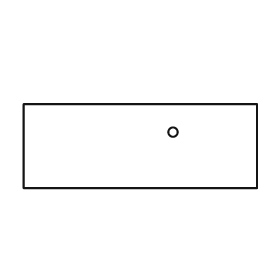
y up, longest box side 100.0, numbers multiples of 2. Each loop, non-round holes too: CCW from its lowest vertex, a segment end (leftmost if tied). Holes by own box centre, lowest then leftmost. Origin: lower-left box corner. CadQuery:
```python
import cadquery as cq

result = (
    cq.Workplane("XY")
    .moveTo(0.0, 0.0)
    .lineTo(100.0, 0.0)
    .lineTo(100.0, 36.0)
    .lineTo(0.0, 36.0)
    .close()
    .moveTo(64.0, 24.0)
    .circle(2.0)
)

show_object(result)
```